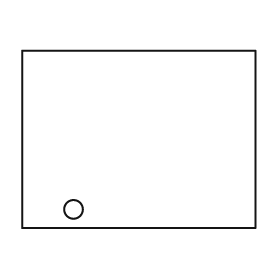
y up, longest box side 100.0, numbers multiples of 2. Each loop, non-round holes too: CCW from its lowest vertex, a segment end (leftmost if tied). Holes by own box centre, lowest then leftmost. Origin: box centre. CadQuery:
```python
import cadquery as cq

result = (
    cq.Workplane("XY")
    .moveTo(-50.0, -38.0)
    .lineTo(50.0, -38.0)
    .lineTo(50.0, 38.0)
    .lineTo(-50.0, 38.0)
    .close()
    .moveTo(-28.0, -30.0)
    .circle(4.0)
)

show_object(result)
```